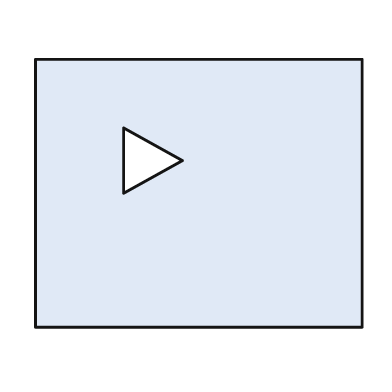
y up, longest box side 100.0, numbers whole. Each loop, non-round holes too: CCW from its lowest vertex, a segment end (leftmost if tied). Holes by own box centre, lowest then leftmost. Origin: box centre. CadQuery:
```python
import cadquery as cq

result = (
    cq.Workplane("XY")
    .moveTo(-50.0, -41.0)
    .lineTo(50.0, -41.0)
    .lineTo(50.0, 41.0)
    .lineTo(-50.0, 41.0)
    .close()
    .moveTo(-23.0, 0.0)
    .lineTo(-5.0, 10.0)
    .lineTo(-23.0, 20.0)
    .close()
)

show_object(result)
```